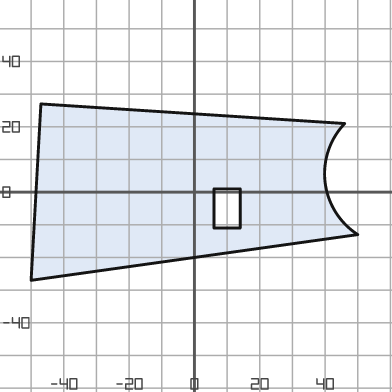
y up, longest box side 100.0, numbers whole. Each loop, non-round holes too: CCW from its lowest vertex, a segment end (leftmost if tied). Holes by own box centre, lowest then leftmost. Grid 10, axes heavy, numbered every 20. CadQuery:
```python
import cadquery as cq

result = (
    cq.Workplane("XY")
    .moveTo(-50.0, -27.0)
    .lineTo(50.0, -13.0)
    .threePointArc((40.0, 3.0), (46.0, 21.0))
    .lineTo(-47.0, 27.0)
    .close()
    .moveTo(6.0, -11.0)
    .lineTo(14.0, -11.0)
    .lineTo(14.0, 1.0)
    .lineTo(6.0, 1.0)
    .close()
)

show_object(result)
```